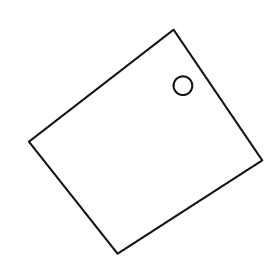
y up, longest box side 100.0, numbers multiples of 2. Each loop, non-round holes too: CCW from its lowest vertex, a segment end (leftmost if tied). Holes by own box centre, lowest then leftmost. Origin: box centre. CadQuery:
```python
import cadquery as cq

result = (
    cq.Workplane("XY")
    .moveTo(-12.0, -48.0)
    .lineTo(50.0, -8.0)
    .lineTo(12.0, 48.0)
    .lineTo(-50.0, 0.0)
    .close()
    .moveTo(16.0, 24.0)
    .circle(4.0)
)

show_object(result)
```